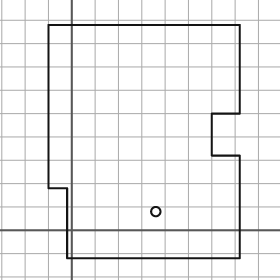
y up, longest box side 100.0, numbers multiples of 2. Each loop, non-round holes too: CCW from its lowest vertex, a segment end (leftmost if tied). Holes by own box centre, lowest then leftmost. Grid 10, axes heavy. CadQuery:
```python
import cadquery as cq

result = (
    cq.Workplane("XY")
    .moveTo(-2.0, -12.0)
    .lineTo(72.0, -12.0)
    .lineTo(72.0, 32.0)
    .lineTo(60.0, 32.0)
    .lineTo(60.0, 50.0)
    .lineTo(72.0, 50.0)
    .lineTo(72.0, 88.0)
    .lineTo(-10.0, 88.0)
    .lineTo(-10.0, 18.0)
    .lineTo(-2.0, 18.0)
    .close()
    .moveTo(36.0, 8.0)
    .circle(2.0)
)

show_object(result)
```